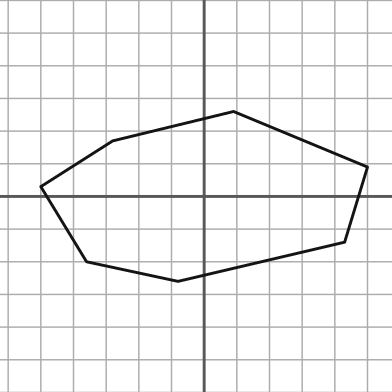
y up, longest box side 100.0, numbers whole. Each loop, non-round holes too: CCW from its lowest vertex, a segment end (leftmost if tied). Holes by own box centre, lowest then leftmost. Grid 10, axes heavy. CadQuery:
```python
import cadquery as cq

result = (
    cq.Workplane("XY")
    .moveTo(-8.0, -26.0)
    .lineTo(43.0, -14.0)
    .lineTo(50.0, 9.0)
    .lineTo(9.0, 26.0)
    .lineTo(-28.0, 17.0)
    .lineTo(-50.0, 3.0)
    .lineTo(-36.0, -20.0)
    .close()
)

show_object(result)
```